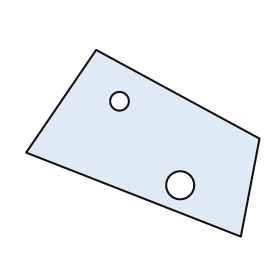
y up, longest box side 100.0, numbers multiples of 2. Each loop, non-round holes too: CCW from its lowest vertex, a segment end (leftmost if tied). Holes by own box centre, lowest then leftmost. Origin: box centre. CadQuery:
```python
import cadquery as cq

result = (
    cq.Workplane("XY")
    .moveTo(42.0, -40.0)
    .lineTo(50.0, 2.0)
    .lineTo(-20.0, 40.0)
    .lineTo(-50.0, -4.0)
    .close()
    .moveTo(16.0, -18.0)
    .circle(6.0)
    .moveTo(-10.0, 18.0)
    .circle(4.0)
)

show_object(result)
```